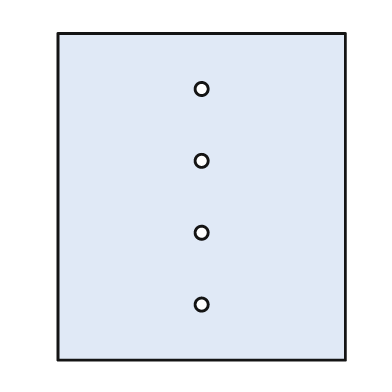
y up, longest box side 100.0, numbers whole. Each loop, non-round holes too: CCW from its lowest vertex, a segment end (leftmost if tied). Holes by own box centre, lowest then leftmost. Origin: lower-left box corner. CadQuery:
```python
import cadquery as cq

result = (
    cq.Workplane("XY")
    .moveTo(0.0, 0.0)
    .lineTo(88.0, 0.0)
    .lineTo(88.0, 100.0)
    .lineTo(0.0, 100.0)
    .close()
    .moveTo(44.0, 17.0)
    .circle(2.0)
    .moveTo(44.0, 39.0)
    .circle(2.0)
    .moveTo(44.0, 61.0)
    .circle(2.0)
    .moveTo(44.0, 83.0)
    .circle(2.0)
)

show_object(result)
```